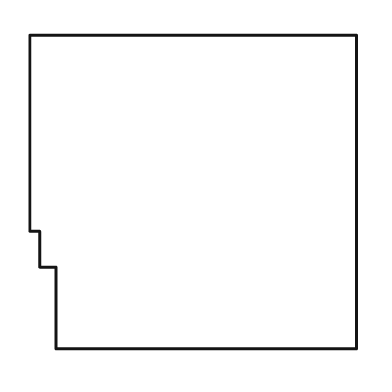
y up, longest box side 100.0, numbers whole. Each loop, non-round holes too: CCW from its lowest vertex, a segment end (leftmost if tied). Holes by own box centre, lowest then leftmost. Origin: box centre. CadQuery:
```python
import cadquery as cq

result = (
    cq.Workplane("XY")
    .moveTo(-42.0, -48.0)
    .lineTo(50.0, -48.0)
    .lineTo(50.0, 48.0)
    .lineTo(-50.0, 48.0)
    .lineTo(-50.0, -12.0)
    .lineTo(-47.0, -12.0)
    .lineTo(-47.0, -23.0)
    .lineTo(-42.0, -23.0)
    .close()
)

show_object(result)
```